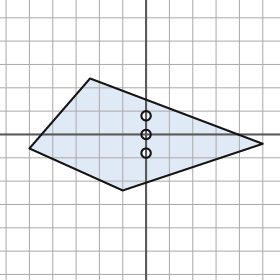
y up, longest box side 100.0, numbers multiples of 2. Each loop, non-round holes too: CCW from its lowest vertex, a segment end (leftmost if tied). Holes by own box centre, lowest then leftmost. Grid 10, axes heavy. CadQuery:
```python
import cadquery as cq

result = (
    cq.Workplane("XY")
    .moveTo(-10.0, -24.0)
    .lineTo(50.0, -4.0)
    .lineTo(-24.0, 24.0)
    .lineTo(-50.0, -6.0)
    .close()
    .moveTo(0.0, -8.0)
    .circle(2.0)
    .moveTo(0.0, 0.0)
    .circle(2.0)
    .moveTo(0.0, 8.0)
    .circle(2.0)
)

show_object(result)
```